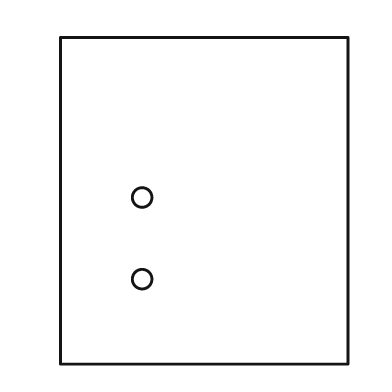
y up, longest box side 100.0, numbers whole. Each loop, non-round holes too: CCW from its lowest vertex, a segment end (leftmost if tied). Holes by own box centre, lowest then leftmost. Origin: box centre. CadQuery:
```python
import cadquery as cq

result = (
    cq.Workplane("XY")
    .moveTo(-44.0, -50.0)
    .lineTo(44.0, -50.0)
    .lineTo(44.0, 50.0)
    .lineTo(-44.0, 50.0)
    .close()
    .moveTo(-19.0, -24.0)
    .circle(3.0)
    .moveTo(-19.0, 1.0)
    .circle(3.0)
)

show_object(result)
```